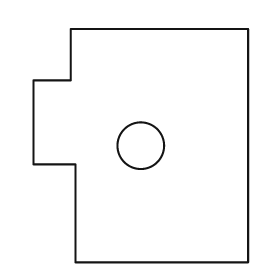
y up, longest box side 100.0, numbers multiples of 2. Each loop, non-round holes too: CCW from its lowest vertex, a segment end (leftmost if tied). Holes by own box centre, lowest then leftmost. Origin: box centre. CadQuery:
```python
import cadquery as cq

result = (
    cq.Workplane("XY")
    .moveTo(-28.0, -50.0)
    .lineTo(46.0, -50.0)
    .lineTo(46.0, 50.0)
    .lineTo(-30.0, 50.0)
    .lineTo(-30.0, 28.0)
    .lineTo(-46.0, 28.0)
    .lineTo(-46.0, -8.0)
    .lineTo(-28.0, -8.0)
    .close()
    .moveTo(0.0, 0.0)
    .circle(10.0)
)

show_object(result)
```